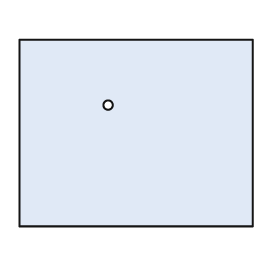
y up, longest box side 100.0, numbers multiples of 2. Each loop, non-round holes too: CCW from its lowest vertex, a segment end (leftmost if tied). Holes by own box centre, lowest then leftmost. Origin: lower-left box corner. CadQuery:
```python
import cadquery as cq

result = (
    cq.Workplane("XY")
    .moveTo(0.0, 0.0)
    .lineTo(100.0, 0.0)
    .lineTo(100.0, 80.0)
    .lineTo(0.0, 80.0)
    .close()
    .moveTo(38.0, 52.0)
    .circle(2.0)
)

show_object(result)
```